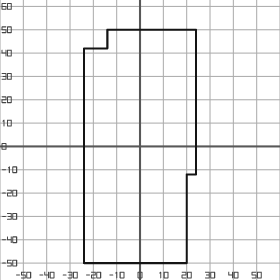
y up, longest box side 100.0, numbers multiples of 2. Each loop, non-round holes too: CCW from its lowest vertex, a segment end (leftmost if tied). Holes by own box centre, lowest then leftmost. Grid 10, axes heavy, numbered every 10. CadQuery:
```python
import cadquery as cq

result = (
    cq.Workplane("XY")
    .moveTo(-24.0, -50.0)
    .lineTo(20.0, -50.0)
    .lineTo(20.0, -12.0)
    .lineTo(24.0, -12.0)
    .lineTo(24.0, 50.0)
    .lineTo(-14.0, 50.0)
    .lineTo(-14.0, 42.0)
    .lineTo(-24.0, 42.0)
    .close()
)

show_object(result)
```